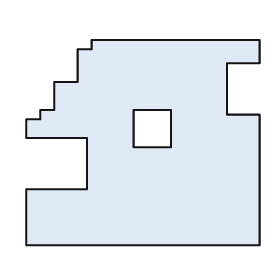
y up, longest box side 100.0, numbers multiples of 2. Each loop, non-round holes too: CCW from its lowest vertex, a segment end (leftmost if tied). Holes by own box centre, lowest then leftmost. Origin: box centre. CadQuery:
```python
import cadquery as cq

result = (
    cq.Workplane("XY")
    .moveTo(-50.0, -44.0)
    .lineTo(50.0, -44.0)
    .lineTo(50.0, 12.0)
    .lineTo(36.0, 12.0)
    .lineTo(36.0, 34.0)
    .lineTo(50.0, 34.0)
    .lineTo(50.0, 44.0)
    .lineTo(-22.0, 44.0)
    .lineTo(-22.0, 40.0)
    .lineTo(-28.0, 40.0)
    .lineTo(-28.0, 26.0)
    .lineTo(-38.0, 26.0)
    .lineTo(-38.0, 14.0)
    .lineTo(-44.0, 14.0)
    .lineTo(-44.0, 10.0)
    .lineTo(-50.0, 10.0)
    .lineTo(-50.0, 2.0)
    .lineTo(-24.0, 2.0)
    .lineTo(-24.0, -20.0)
    .lineTo(-50.0, -20.0)
    .close()
    .moveTo(-4.0, -2.0)
    .lineTo(12.0, -2.0)
    .lineTo(12.0, 14.0)
    .lineTo(-4.0, 14.0)
    .close()
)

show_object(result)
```